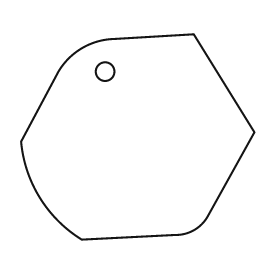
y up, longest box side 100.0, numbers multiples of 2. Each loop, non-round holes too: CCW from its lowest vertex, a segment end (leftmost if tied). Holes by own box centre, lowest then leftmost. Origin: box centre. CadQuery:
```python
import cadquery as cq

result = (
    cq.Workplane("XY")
    .moveTo(-24.0, -44.0)
    .lineTo(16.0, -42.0)
    .threePointArc((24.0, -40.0), (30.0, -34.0))
    .lineTo(50.0, 2.0)
    .lineTo(24.0, 44.0)
    .lineTo(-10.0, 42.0)
    .threePointArc((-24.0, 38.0), (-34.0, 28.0))
    .lineTo(-50.0, -2.0)
    .threePointArc((-42.0, -26.0), (-24.0, -44.0))
    .close()
    .moveTo(-14.0, 28.0)
    .circle(4.0)
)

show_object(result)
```